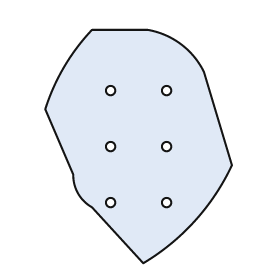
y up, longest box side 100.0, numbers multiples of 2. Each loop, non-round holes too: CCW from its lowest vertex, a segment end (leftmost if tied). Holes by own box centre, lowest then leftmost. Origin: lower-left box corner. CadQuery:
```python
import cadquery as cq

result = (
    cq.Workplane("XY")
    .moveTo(42.0, 0.0)
    .threePointArc((64.0, 18.0), (80.0, 42.0))
    .lineTo(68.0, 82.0)
    .threePointArc((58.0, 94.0), (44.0, 100.0))
    .lineTo(20.0, 100.0)
    .threePointArc((8.0, 84.0), (0.0, 66.0))
    .lineTo(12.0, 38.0)
    .threePointArc((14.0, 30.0), (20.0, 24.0))
    .close()
    .moveTo(28.0, 26.0)
    .circle(2.0)
    .moveTo(52.0, 26.0)
    .circle(2.0)
    .moveTo(28.0, 50.0)
    .circle(2.0)
    .moveTo(52.0, 50.0)
    .circle(2.0)
    .moveTo(28.0, 74.0)
    .circle(2.0)
    .moveTo(52.0, 74.0)
    .circle(2.0)
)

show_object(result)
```